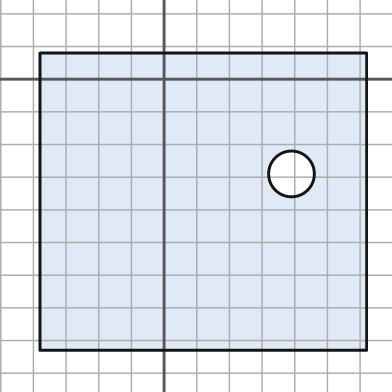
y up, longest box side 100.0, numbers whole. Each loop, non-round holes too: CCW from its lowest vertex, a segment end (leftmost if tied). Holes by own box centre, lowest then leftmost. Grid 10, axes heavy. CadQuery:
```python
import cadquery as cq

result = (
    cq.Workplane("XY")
    .moveTo(-38.0, -83.0)
    .lineTo(62.0, -83.0)
    .lineTo(62.0, 8.0)
    .lineTo(-38.0, 8.0)
    .close()
    .moveTo(39.0, -29.0)
    .circle(7.0)
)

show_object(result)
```